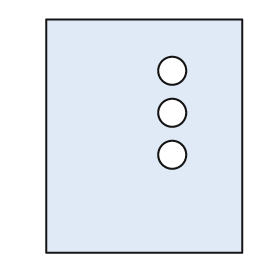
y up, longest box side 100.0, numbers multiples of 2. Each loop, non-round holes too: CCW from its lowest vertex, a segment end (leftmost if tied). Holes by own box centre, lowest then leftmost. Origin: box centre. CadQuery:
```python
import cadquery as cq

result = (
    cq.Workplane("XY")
    .moveTo(-42.0, -50.0)
    .lineTo(42.0, -50.0)
    .lineTo(42.0, 50.0)
    .lineTo(-42.0, 50.0)
    .close()
    .moveTo(12.0, -8.0)
    .circle(6.0)
    .moveTo(12.0, 10.0)
    .circle(6.0)
    .moveTo(12.0, 28.0)
    .circle(6.0)
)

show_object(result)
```